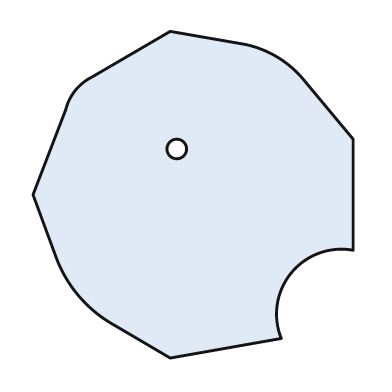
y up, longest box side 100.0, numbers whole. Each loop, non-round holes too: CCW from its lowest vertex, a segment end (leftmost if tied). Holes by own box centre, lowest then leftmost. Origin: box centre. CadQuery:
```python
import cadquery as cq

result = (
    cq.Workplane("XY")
    .moveTo(-7.0, -50.0)
    .lineTo(27.0, -44.0)
    .threePointArc((30.0, -24.0), (49.0, -17.0))
    .lineTo(49.0, 17.0)
    .lineTo(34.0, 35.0)
    .threePointArc((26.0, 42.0), (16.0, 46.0))
    .lineTo(-7.0, 50.0)
    .lineTo(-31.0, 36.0)
    .threePointArc((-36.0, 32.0), (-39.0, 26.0))
    .lineTo(-49.0, 0.0)
    .lineTo(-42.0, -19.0)
    .threePointArc((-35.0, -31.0), (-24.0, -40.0))
    .close()
    .moveTo(-5.0, 14.0)
    .circle(3.0)
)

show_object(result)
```